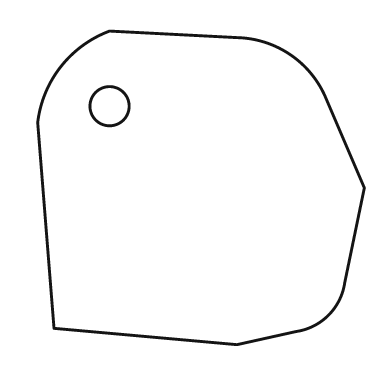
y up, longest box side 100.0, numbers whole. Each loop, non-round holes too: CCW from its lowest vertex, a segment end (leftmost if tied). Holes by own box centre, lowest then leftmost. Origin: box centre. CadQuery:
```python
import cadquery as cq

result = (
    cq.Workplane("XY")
    .moveTo(11.0, -48.0)
    .lineTo(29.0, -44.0)
    .threePointArc((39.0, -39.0), (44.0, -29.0))
    .lineTo(50.0, 0.0)
    .lineTo(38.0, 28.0)
    .threePointArc((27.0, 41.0), (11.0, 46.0))
    .lineTo(-28.0, 48.0)
    .threePointArc((-43.0, 37.0), (-50.0, 20.0))
    .lineTo(-45.0, -43.0)
    .close()
    .moveTo(-28.0, 25.0)
    .circle(6.0)
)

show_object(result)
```